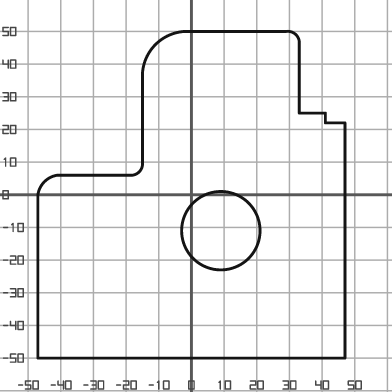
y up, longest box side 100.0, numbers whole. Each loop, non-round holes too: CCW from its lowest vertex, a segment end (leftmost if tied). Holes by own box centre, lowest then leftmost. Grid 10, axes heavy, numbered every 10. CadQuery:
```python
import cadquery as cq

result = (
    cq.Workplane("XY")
    .moveTo(-47.0, -50.0)
    .lineTo(47.0, -50.0)
    .lineTo(47.0, 22.0)
    .lineTo(41.0, 22.0)
    .lineTo(41.0, 25.0)
    .lineTo(33.0, 25.0)
    .lineTo(33.0, 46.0)
    .threePointArc((32.0, 49.0), (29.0, 50.0))
    .lineTo(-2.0, 50.0)
    .threePointArc((-11.0, 46.0), (-15.0, 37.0))
    .lineTo(-15.0, 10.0)
    .threePointArc((-16.0, 7.0), (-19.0, 6.0))
    .lineTo(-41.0, 6.0)
    .threePointArc((-45.0, 4.0), (-47.0, 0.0))
    .close()
    .moveTo(9.0, -11.0)
    .circle(12.0)
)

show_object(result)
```